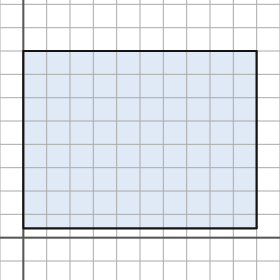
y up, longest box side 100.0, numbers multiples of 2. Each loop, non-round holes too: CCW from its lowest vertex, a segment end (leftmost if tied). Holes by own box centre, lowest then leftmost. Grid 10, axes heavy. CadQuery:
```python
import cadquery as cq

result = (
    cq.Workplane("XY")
    .moveTo(0.0, 4.0)
    .lineTo(100.0, 4.0)
    .lineTo(100.0, 80.0)
    .lineTo(0.0, 80.0)
    .close()
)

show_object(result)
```